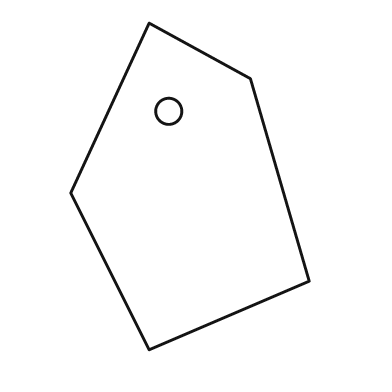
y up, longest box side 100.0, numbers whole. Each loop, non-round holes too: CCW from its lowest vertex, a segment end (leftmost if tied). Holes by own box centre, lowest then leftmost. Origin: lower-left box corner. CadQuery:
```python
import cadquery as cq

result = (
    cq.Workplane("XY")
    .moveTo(24.0, 0.0)
    .lineTo(73.0, 21.0)
    .lineTo(55.0, 83.0)
    .lineTo(24.0, 100.0)
    .lineTo(0.0, 48.0)
    .close()
    .moveTo(30.0, 73.0)
    .circle(4.0)
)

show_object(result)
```